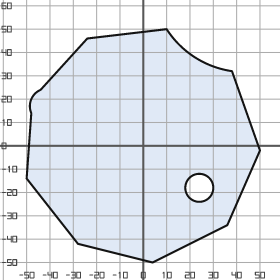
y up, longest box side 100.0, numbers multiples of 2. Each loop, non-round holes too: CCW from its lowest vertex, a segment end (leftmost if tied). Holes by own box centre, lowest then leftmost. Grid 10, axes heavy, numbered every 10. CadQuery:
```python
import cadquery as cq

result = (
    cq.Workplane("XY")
    .moveTo(4.0, -50.0)
    .lineTo(36.0, -34.0)
    .lineTo(50.0, -2.0)
    .lineTo(38.0, 32.0)
    .threePointArc((22.0, 38.0), (10.0, 50.0))
    .lineTo(-24.0, 46.0)
    .lineTo(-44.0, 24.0)
    .threePointArc((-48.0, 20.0), (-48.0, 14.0))
    .lineTo(-50.0, -14.0)
    .lineTo(-28.0, -42.0)
    .close()
    .moveTo(24.0, -18.0)
    .circle(6.0)
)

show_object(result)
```